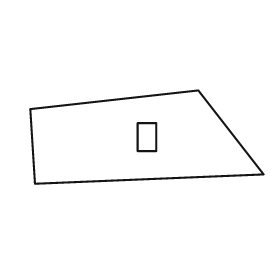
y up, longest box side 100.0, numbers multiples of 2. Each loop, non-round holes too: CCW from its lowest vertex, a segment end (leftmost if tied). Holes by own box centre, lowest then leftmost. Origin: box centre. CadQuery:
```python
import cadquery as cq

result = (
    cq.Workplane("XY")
    .moveTo(-48.0, -20.0)
    .lineTo(50.0, -16.0)
    .lineTo(22.0, 20.0)
    .lineTo(-50.0, 12.0)
    .close()
    .moveTo(-4.0, -6.0)
    .lineTo(4.0, -6.0)
    .lineTo(4.0, 6.0)
    .lineTo(-4.0, 6.0)
    .close()
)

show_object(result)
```